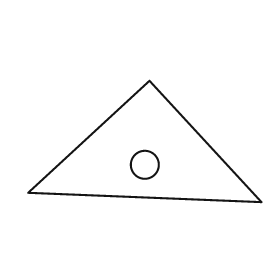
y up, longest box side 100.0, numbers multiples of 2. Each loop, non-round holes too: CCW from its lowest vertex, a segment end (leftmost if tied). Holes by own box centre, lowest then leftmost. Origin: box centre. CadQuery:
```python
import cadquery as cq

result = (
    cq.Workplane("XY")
    .moveTo(50.0, -26.0)
    .lineTo(2.0, 26.0)
    .lineTo(-50.0, -22.0)
    .close()
    .moveTo(0.0, -10.0)
    .circle(6.0)
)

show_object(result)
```